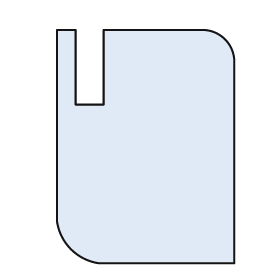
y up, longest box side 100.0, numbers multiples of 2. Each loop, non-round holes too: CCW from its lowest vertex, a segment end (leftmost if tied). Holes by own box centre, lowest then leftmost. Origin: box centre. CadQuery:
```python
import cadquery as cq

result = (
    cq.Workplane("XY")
    .moveTo(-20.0, -50.0)
    .lineTo(38.0, -50.0)
    .lineTo(38.0, 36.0)
    .threePointArc((34.0, 46.0), (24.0, 50.0))
    .lineTo(-18.0, 50.0)
    .lineTo(-18.0, 18.0)
    .lineTo(-30.0, 18.0)
    .lineTo(-30.0, 50.0)
    .lineTo(-38.0, 50.0)
    .lineTo(-38.0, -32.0)
    .threePointArc((-32.0, -44.0), (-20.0, -50.0))
    .close()
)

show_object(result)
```